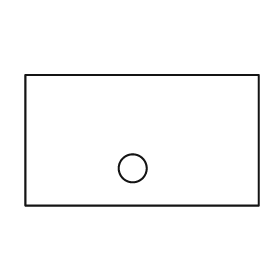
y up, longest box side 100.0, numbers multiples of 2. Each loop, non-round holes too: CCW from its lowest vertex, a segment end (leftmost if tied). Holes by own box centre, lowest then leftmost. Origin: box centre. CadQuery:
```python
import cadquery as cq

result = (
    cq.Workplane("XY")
    .moveTo(-50.0, -28.0)
    .lineTo(50.0, -28.0)
    .lineTo(50.0, 28.0)
    .lineTo(-50.0, 28.0)
    .close()
    .moveTo(-4.0, -12.0)
    .circle(6.0)
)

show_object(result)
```